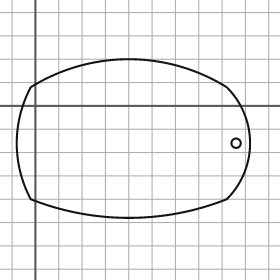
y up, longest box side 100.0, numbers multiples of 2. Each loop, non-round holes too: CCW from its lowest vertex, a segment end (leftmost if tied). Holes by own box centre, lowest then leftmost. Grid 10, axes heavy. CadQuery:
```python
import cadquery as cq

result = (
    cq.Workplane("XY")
    .moveTo(-2.0, -40.0)
    .threePointArc((40.0, -48.0), (82.0, -40.0))
    .threePointArc((92.0, -16.0), (82.0, 8.0))
    .threePointArc((40.0, 20.0), (-2.0, 8.0))
    .threePointArc((-8.0, -16.0), (-2.0, -40.0))
    .close()
    .moveTo(86.0, -16.0)
    .circle(2.0)
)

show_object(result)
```